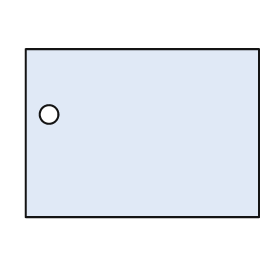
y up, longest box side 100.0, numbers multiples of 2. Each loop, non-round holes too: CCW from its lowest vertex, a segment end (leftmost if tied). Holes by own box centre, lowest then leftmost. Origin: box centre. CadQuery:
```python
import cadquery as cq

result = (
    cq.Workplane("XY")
    .moveTo(-50.0, -36.0)
    .lineTo(50.0, -36.0)
    .lineTo(50.0, 36.0)
    .lineTo(-50.0, 36.0)
    .close()
    .moveTo(-40.0, 8.0)
    .circle(4.0)
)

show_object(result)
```